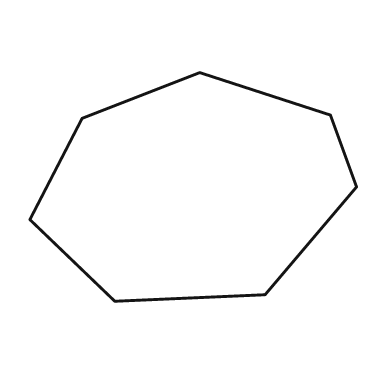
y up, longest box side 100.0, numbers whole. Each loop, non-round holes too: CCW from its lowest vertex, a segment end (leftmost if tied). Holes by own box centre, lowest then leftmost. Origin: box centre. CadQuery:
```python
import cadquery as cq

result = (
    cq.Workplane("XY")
    .moveTo(-24.0, -35.0)
    .lineTo(22.0, -33.0)
    .lineTo(50.0, 0.0)
    .lineTo(42.0, 22.0)
    .lineTo(2.0, 35.0)
    .lineTo(-34.0, 21.0)
    .lineTo(-50.0, -10.0)
    .close()
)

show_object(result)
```